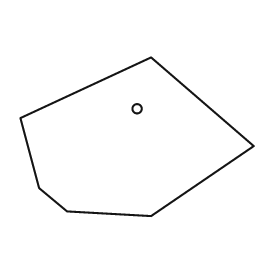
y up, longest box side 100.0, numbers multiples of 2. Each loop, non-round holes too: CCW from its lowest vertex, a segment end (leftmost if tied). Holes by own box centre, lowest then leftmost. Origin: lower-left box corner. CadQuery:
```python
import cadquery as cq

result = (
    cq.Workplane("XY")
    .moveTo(56.0, 0.0)
    .lineTo(100.0, 30.0)
    .lineTo(56.0, 68.0)
    .lineTo(0.0, 42.0)
    .lineTo(8.0, 12.0)
    .lineTo(20.0, 2.0)
    .close()
    .moveTo(50.0, 46.0)
    .circle(2.0)
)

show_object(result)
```